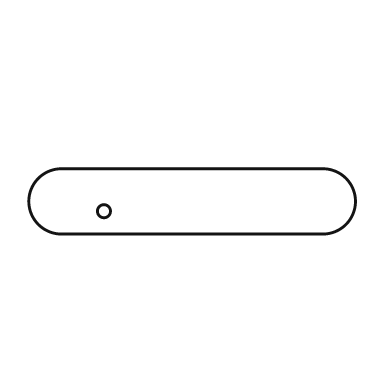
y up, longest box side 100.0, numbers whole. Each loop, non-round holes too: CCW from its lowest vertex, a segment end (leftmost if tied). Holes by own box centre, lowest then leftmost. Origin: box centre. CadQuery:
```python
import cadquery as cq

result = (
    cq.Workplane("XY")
    .moveTo(-40.0, -10.0)
    .lineTo(40.0, -10.0)
    .threePointArc((50.0, 0.0), (40.0, 10.0))
    .lineTo(-40.0, 10.0)
    .threePointArc((-50.0, 0.0), (-40.0, -10.0))
    .close()
    .moveTo(-27.0, -3.0)
    .circle(2.0)
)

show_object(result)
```